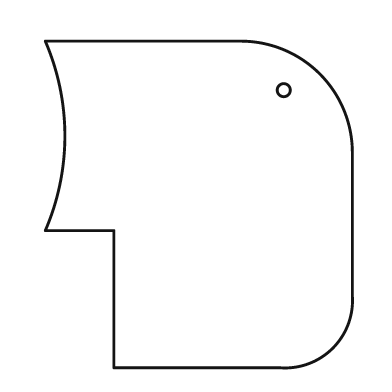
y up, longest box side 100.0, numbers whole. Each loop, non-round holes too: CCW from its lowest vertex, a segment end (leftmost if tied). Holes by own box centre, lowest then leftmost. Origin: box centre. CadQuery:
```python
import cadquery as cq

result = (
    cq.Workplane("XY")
    .moveTo(-26.0, -50.0)
    .lineTo(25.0, -50.0)
    .threePointArc((41.0, -44.0), (47.0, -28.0))
    .lineTo(47.0, 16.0)
    .threePointArc((37.0, 40.0), (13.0, 50.0))
    .lineTo(-47.0, 50.0)
    .threePointArc((-41.0, 21.0), (-47.0, -8.0))
    .lineTo(-26.0, -8.0)
    .close()
    .moveTo(26.0, 35.0)
    .circle(2.0)
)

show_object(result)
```